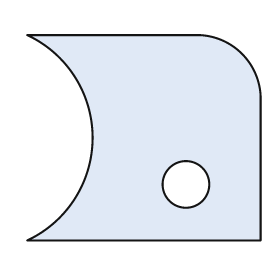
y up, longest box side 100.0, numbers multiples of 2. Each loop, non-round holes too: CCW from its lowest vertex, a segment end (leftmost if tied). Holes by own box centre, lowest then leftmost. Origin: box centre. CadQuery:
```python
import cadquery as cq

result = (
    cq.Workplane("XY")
    .moveTo(-50.0, -44.0)
    .lineTo(50.0, -44.0)
    .lineTo(50.0, 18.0)
    .threePointArc((42.0, 36.0), (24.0, 44.0))
    .lineTo(-50.0, 44.0)
    .threePointArc((-22.0, 0.0), (-50.0, -44.0))
    .close()
    .moveTo(18.0, -20.0)
    .circle(10.0)
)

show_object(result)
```